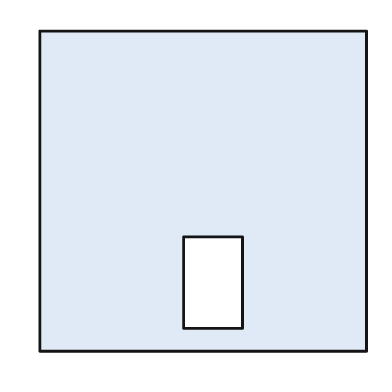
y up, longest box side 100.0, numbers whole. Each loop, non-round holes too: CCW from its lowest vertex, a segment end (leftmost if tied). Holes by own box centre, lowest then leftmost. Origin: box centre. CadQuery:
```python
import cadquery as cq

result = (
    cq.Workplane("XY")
    .moveTo(-50.0, -49.0)
    .lineTo(50.0, -49.0)
    .lineTo(50.0, 49.0)
    .lineTo(-50.0, 49.0)
    .close()
    .moveTo(-6.0, -42.0)
    .lineTo(12.0, -42.0)
    .lineTo(12.0, -14.0)
    .lineTo(-6.0, -14.0)
    .close()
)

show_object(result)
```